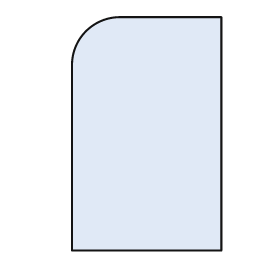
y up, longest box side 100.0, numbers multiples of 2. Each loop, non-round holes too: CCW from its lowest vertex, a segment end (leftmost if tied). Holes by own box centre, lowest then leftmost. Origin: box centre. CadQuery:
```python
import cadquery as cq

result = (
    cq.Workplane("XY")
    .moveTo(-32.0, -50.0)
    .lineTo(32.0, -50.0)
    .lineTo(32.0, 50.0)
    .lineTo(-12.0, 50.0)
    .threePointArc((-26.0, 44.0), (-32.0, 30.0))
    .close()
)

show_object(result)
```